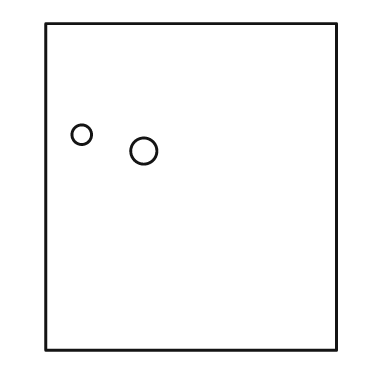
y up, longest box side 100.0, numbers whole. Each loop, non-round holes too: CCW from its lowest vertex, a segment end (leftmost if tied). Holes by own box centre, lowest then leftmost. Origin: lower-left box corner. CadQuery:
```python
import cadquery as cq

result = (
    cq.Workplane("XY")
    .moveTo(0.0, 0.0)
    .lineTo(89.0, 0.0)
    .lineTo(89.0, 100.0)
    .lineTo(0.0, 100.0)
    .close()
    .moveTo(30.0, 61.0)
    .circle(4.0)
    .moveTo(11.0, 66.0)
    .circle(3.0)
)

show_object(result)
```